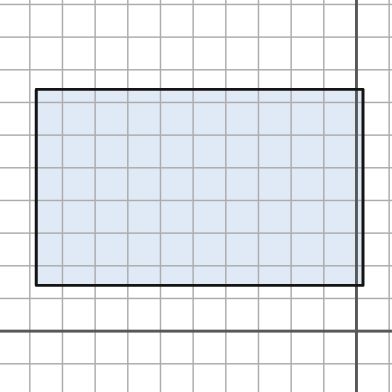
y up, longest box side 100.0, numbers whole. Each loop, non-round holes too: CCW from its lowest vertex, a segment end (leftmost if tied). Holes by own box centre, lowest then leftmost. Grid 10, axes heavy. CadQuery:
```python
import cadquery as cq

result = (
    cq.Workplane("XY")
    .moveTo(-98.0, 14.0)
    .lineTo(2.0, 14.0)
    .lineTo(2.0, 74.0)
    .lineTo(-98.0, 74.0)
    .close()
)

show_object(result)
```